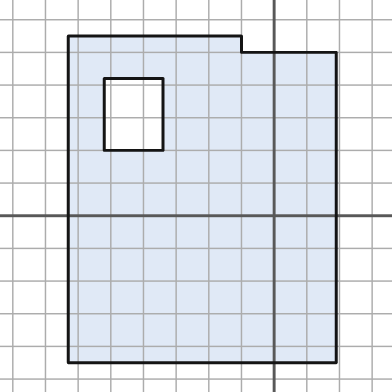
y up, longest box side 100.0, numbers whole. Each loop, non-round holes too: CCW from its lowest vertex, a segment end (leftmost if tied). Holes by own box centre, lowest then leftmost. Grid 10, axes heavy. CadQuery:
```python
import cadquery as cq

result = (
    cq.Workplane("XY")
    .moveTo(-63.0, -45.0)
    .lineTo(19.0, -45.0)
    .lineTo(19.0, 50.0)
    .lineTo(-10.0, 50.0)
    .lineTo(-10.0, 55.0)
    .lineTo(-63.0, 55.0)
    .close()
    .moveTo(-52.0, 20.0)
    .lineTo(-34.0, 20.0)
    .lineTo(-34.0, 42.0)
    .lineTo(-52.0, 42.0)
    .close()
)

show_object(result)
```